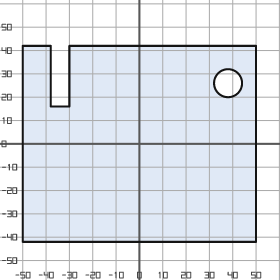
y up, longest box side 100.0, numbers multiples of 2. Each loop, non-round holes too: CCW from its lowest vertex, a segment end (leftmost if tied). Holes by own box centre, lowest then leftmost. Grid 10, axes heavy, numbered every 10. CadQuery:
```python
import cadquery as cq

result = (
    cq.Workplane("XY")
    .moveTo(-50.0, -42.0)
    .lineTo(50.0, -42.0)
    .lineTo(50.0, 42.0)
    .lineTo(-30.0, 42.0)
    .lineTo(-30.0, 16.0)
    .lineTo(-38.0, 16.0)
    .lineTo(-38.0, 42.0)
    .lineTo(-50.0, 42.0)
    .close()
    .moveTo(38.0, 26.0)
    .circle(6.0)
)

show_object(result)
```